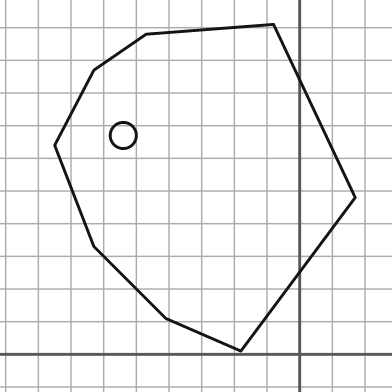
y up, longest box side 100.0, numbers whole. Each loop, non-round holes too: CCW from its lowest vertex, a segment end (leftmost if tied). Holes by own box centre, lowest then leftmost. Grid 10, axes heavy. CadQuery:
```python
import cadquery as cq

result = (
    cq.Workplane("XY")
    .moveTo(-18.0, 1.0)
    .lineTo(17.0, 48.0)
    .lineTo(-8.0, 101.0)
    .lineTo(-47.0, 98.0)
    .lineTo(-63.0, 87.0)
    .lineTo(-75.0, 64.0)
    .lineTo(-63.0, 33.0)
    .lineTo(-41.0, 11.0)
    .close()
    .moveTo(-54.0, 67.0)
    .circle(4.0)
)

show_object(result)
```